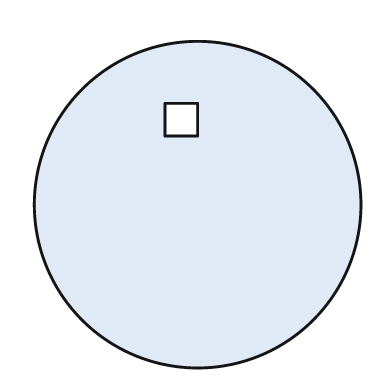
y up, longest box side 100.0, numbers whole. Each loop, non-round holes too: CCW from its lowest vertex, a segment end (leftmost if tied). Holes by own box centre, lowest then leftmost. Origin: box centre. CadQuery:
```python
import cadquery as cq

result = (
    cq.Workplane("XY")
    .moveTo(0.0, 0.0)
    .circle(50.0)
    .moveTo(-10.0, 21.0)
    .lineTo(0.0, 21.0)
    .lineTo(0.0, 31.0)
    .lineTo(-10.0, 31.0)
    .close()
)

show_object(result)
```